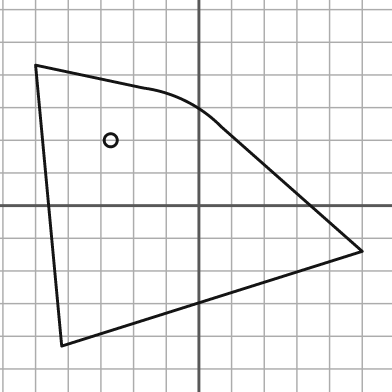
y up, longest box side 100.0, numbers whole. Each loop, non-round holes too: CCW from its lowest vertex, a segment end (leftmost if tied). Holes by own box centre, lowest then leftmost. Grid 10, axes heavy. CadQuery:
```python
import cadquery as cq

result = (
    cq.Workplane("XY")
    .moveTo(-42.0, -43.0)
    .lineTo(50.0, -14.0)
    .lineTo(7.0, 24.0)
    .threePointArc((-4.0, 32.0), (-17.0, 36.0))
    .lineTo(-50.0, 43.0)
    .close()
    .moveTo(-27.0, 20.0)
    .circle(2.0)
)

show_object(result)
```